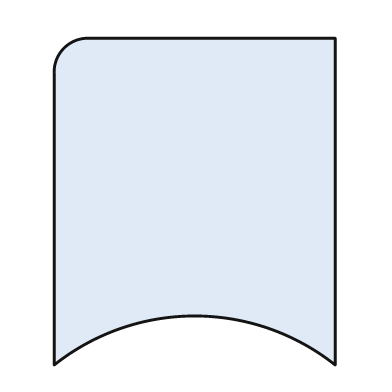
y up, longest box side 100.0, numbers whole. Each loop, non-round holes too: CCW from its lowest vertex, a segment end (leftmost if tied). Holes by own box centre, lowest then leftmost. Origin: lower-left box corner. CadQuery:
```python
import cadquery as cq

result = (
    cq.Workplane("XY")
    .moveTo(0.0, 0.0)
    .threePointArc((43.0, 15.0), (86.0, 0.0))
    .lineTo(86.0, 100.0)
    .lineTo(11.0, 100.0)
    .threePointArc((3.0, 97.0), (0.0, 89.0))
    .close()
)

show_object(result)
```